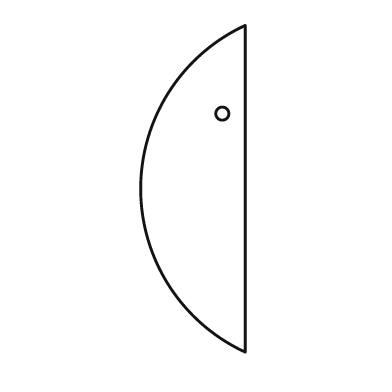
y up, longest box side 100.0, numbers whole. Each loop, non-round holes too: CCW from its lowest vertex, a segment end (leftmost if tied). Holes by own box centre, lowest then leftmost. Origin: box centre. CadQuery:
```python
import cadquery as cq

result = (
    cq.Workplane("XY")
    .moveTo(16.0, -50.0)
    .lineTo(16.0, 50.0)
    .threePointArc((-16.0, 0.0), (16.0, -50.0))
    .close()
    .moveTo(9.0, 23.0)
    .circle(2.0)
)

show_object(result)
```